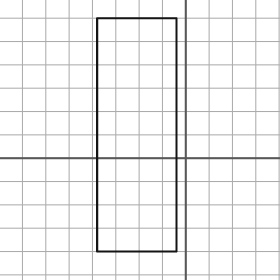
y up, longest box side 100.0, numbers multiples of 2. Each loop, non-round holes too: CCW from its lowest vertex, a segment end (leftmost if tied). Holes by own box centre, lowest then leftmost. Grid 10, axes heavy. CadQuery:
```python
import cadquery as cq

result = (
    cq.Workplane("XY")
    .moveTo(-38.0, -40.0)
    .lineTo(-4.0, -40.0)
    .lineTo(-4.0, 60.0)
    .lineTo(-38.0, 60.0)
    .close()
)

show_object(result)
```